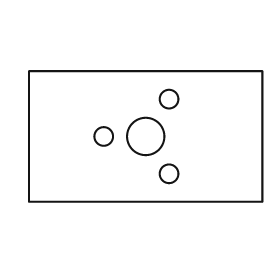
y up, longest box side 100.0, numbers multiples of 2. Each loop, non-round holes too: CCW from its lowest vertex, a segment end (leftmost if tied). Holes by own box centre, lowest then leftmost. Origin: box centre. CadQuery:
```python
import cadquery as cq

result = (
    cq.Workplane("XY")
    .moveTo(-50.0, -28.0)
    .lineTo(50.0, -28.0)
    .lineTo(50.0, 28.0)
    .lineTo(-50.0, 28.0)
    .close()
    .moveTo(10.0, -16.0)
    .circle(4.0)
    .moveTo(-18.0, 0.0)
    .circle(4.0)
    .moveTo(0.0, 0.0)
    .circle(8.0)
    .moveTo(10.0, 16.0)
    .circle(4.0)
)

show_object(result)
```